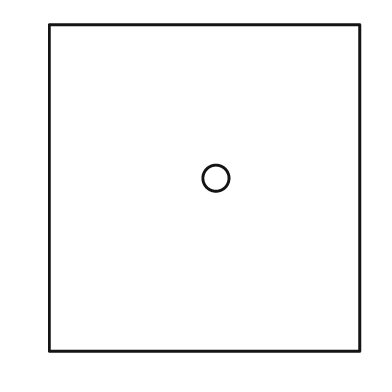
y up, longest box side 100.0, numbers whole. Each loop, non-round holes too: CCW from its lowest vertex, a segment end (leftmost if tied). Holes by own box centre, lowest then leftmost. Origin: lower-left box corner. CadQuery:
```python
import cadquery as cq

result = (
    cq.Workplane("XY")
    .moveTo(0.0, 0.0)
    .lineTo(95.0, 0.0)
    .lineTo(95.0, 100.0)
    .lineTo(0.0, 100.0)
    .close()
    .moveTo(51.0, 53.0)
    .circle(4.0)
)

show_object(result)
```